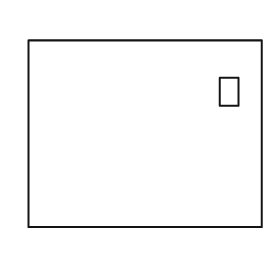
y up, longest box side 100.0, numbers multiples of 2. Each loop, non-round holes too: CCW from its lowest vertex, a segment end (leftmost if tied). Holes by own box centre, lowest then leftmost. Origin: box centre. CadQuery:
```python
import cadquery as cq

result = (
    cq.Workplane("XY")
    .moveTo(-50.0, -40.0)
    .lineTo(50.0, -40.0)
    .lineTo(50.0, 40.0)
    .lineTo(-50.0, 40.0)
    .close()
    .moveTo(32.0, 12.0)
    .lineTo(40.0, 12.0)
    .lineTo(40.0, 24.0)
    .lineTo(32.0, 24.0)
    .close()
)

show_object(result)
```